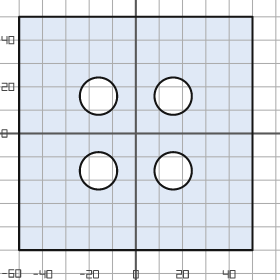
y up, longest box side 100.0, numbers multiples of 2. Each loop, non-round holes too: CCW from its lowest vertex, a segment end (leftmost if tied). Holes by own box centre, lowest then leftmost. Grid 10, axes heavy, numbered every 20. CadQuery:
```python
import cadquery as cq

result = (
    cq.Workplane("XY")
    .moveTo(-50.0, -50.0)
    .lineTo(50.0, -50.0)
    .lineTo(50.0, 50.0)
    .lineTo(-50.0, 50.0)
    .close()
    .moveTo(-16.0, -16.0)
    .circle(8.0)
    .moveTo(16.0, -16.0)
    .circle(8.0)
    .moveTo(-16.0, 16.0)
    .circle(8.0)
    .moveTo(16.0, 16.0)
    .circle(8.0)
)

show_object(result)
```